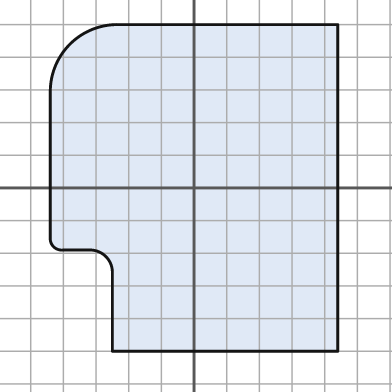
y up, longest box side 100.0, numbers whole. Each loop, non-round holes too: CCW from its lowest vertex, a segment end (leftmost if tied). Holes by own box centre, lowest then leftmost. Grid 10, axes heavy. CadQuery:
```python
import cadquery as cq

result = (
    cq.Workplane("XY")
    .moveTo(-25.0, -50.0)
    .lineTo(44.0, -50.0)
    .lineTo(44.0, 50.0)
    .lineTo(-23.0, 50.0)
    .threePointArc((-38.0, 44.0), (-44.0, 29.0))
    .lineTo(-44.0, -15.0)
    .threePointArc((-43.0, -18.0), (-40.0, -19.0))
    .lineTo(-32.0, -19.0)
    .threePointArc((-27.0, -21.0), (-25.0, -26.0))
    .close()
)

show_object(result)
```